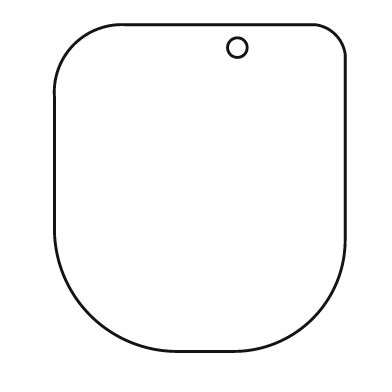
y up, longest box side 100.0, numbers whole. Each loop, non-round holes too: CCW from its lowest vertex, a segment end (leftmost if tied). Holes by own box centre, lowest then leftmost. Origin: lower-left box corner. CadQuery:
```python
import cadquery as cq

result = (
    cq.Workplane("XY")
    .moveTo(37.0, 0.0)
    .lineTo(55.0, 0.0)
    .threePointArc((79.0, 10.0), (89.0, 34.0))
    .lineTo(89.0, 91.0)
    .threePointArc((86.0, 97.0), (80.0, 100.0))
    .lineTo(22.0, 100.0)
    .threePointArc((6.0, 94.0), (0.0, 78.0))
    .lineTo(0.0, 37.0)
    .threePointArc((11.0, 11.0), (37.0, 0.0))
    .close()
    .moveTo(56.0, 93.0)
    .circle(3.0)
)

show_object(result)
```